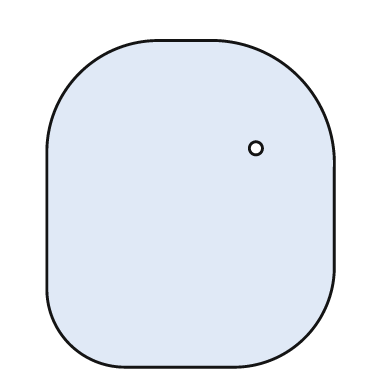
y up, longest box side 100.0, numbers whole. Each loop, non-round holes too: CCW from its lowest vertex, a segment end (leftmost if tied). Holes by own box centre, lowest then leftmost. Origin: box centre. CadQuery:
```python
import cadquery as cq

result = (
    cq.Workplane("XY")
    .moveTo(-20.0, -50.0)
    .lineTo(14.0, -50.0)
    .threePointArc((35.0, -41.0), (44.0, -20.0))
    .lineTo(44.0, 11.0)
    .threePointArc((33.0, 39.0), (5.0, 50.0))
    .lineTo(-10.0, 50.0)
    .threePointArc((-34.0, 40.0), (-44.0, 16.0))
    .lineTo(-44.0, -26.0)
    .threePointArc((-37.0, -43.0), (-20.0, -50.0))
    .close()
    .moveTo(20.0, 17.0)
    .circle(2.0)
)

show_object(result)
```